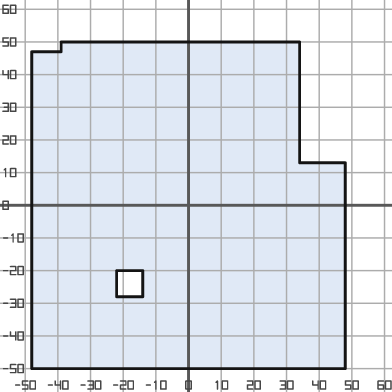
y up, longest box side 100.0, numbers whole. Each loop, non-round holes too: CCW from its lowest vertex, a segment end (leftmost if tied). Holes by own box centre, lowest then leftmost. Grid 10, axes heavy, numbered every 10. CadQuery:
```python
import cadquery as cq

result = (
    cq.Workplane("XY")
    .moveTo(-48.0, -50.0)
    .lineTo(48.0, -50.0)
    .lineTo(48.0, 13.0)
    .lineTo(34.0, 13.0)
    .lineTo(34.0, 50.0)
    .lineTo(-39.0, 50.0)
    .lineTo(-39.0, 47.0)
    .lineTo(-48.0, 47.0)
    .close()
    .moveTo(-22.0, -28.0)
    .lineTo(-14.0, -28.0)
    .lineTo(-14.0, -20.0)
    .lineTo(-22.0, -20.0)
    .close()
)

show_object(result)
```